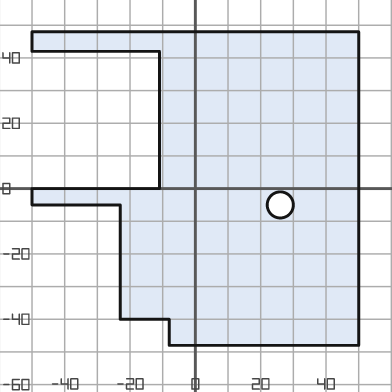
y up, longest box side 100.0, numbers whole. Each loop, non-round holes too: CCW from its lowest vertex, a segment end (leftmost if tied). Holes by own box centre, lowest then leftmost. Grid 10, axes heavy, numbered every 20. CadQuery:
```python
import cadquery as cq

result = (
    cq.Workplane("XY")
    .moveTo(-8.0, -48.0)
    .lineTo(50.0, -48.0)
    .lineTo(50.0, 48.0)
    .lineTo(-50.0, 48.0)
    .lineTo(-50.0, 42.0)
    .lineTo(-11.0, 42.0)
    .lineTo(-11.0, 0.0)
    .lineTo(-50.0, 0.0)
    .lineTo(-50.0, -5.0)
    .lineTo(-23.0, -5.0)
    .lineTo(-23.0, -40.0)
    .lineTo(-8.0, -40.0)
    .close()
    .moveTo(26.0, -5.0)
    .circle(4.0)
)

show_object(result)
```